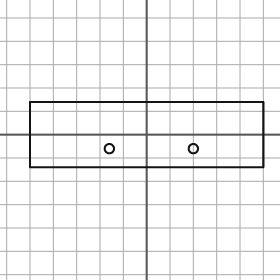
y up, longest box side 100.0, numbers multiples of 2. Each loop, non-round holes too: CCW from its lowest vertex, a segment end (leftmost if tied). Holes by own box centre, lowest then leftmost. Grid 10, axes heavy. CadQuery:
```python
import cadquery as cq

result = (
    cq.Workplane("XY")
    .moveTo(-50.0, -14.0)
    .lineTo(50.0, -14.0)
    .lineTo(50.0, 14.0)
    .lineTo(-50.0, 14.0)
    .close()
    .moveTo(-16.0, -6.0)
    .circle(2.0)
    .moveTo(20.0, -6.0)
    .circle(2.0)
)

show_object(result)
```